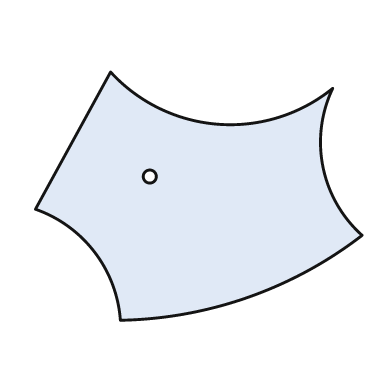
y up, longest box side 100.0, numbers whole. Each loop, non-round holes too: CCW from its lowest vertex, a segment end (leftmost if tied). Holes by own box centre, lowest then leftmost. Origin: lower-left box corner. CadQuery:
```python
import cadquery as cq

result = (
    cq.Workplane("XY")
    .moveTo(26.0, 0.0)
    .threePointArc((65.0, 7.0), (100.0, 26.0))
    .threePointArc((88.0, 47.0), (91.0, 71.0))
    .threePointArc((56.0, 60.0), (23.0, 76.0))
    .lineTo(0.0, 34.0)
    .threePointArc((18.0, 21.0), (26.0, 0.0))
    .close()
    .moveTo(35.0, 44.0)
    .circle(2.0)
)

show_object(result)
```